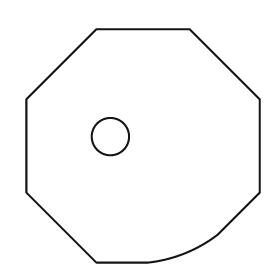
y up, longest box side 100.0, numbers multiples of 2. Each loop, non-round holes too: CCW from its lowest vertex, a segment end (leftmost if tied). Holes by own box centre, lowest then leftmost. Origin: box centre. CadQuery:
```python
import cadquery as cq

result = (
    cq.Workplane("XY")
    .moveTo(-20.0, -50.0)
    .lineTo(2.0, -50.0)
    .threePointArc((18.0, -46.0), (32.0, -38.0))
    .lineTo(50.0, -20.0)
    .lineTo(50.0, 20.0)
    .lineTo(20.0, 50.0)
    .lineTo(-20.0, 50.0)
    .lineTo(-50.0, 20.0)
    .lineTo(-50.0, -20.0)
    .close()
    .moveTo(-14.0, 4.0)
    .circle(8.0)
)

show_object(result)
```